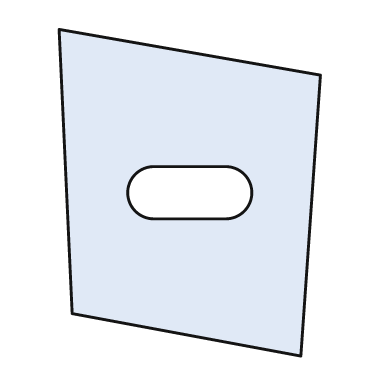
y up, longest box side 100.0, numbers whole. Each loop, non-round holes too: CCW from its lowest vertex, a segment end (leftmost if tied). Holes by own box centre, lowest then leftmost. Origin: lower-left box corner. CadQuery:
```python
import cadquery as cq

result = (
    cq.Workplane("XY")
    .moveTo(74.0, 0.0)
    .lineTo(80.0, 86.0)
    .lineTo(0.0, 100.0)
    .lineTo(4.0, 13.0)
    .close()
    .moveTo(29.0, 42.0)
    .lineTo(51.0, 42.0)
    .threePointArc((59.0, 50.0), (51.0, 58.0))
    .lineTo(29.0, 58.0)
    .threePointArc((21.0, 50.0), (29.0, 42.0))
    .close()
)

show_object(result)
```